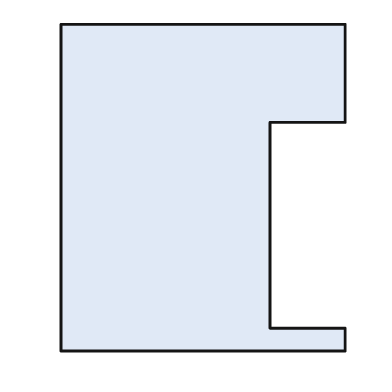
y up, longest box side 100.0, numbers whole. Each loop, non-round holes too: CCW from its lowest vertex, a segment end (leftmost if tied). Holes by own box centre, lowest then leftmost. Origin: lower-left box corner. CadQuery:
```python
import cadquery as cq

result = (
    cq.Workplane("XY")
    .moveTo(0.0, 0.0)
    .lineTo(87.0, 0.0)
    .lineTo(87.0, 7.0)
    .lineTo(64.0, 7.0)
    .lineTo(64.0, 70.0)
    .lineTo(87.0, 70.0)
    .lineTo(87.0, 100.0)
    .lineTo(0.0, 100.0)
    .close()
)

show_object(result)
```